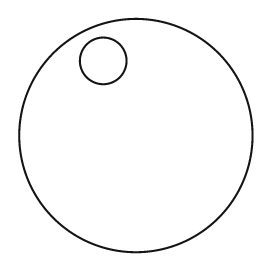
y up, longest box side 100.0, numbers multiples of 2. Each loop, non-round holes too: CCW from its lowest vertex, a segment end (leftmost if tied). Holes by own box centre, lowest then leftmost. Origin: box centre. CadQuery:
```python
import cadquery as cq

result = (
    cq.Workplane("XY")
    .moveTo(0.0, 0.0)
    .circle(50.0)
    .moveTo(-14.0, 32.0)
    .circle(10.0)
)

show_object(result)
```